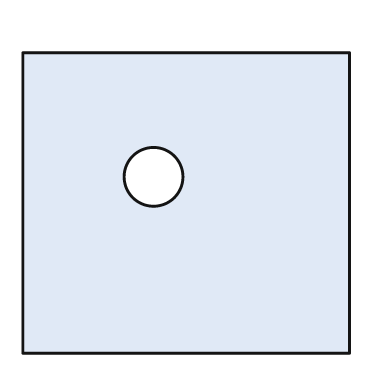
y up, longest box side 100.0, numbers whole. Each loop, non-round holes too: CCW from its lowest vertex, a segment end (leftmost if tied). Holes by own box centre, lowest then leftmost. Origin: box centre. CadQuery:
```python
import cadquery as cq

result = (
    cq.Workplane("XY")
    .moveTo(-50.0, -46.0)
    .lineTo(50.0, -46.0)
    .lineTo(50.0, 46.0)
    .lineTo(-50.0, 46.0)
    .close()
    .moveTo(-10.0, 8.0)
    .circle(9.0)
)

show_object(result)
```